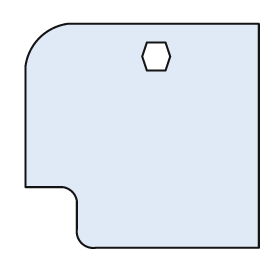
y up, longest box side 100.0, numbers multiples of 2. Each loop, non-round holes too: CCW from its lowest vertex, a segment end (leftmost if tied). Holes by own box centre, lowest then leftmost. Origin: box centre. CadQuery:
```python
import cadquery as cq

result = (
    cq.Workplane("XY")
    .moveTo(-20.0, -48.0)
    .lineTo(50.0, -48.0)
    .lineTo(50.0, 48.0)
    .lineTo(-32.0, 48.0)
    .threePointArc((-44.0, 42.0), (-50.0, 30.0))
    .lineTo(-50.0, -22.0)
    .lineTo(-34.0, -22.0)
    .threePointArc((-30.0, -24.0), (-28.0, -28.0))
    .lineTo(-28.0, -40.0)
    .threePointArc((-26.0, -46.0), (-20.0, -48.0))
    .close()
    .moveTo(2.0, 28.0)
    .lineTo(10.0, 28.0)
    .lineTo(12.0, 34.0)
    .lineTo(10.0, 40.0)
    .lineTo(2.0, 40.0)
    .lineTo(0.0, 34.0)
    .close()
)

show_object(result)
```